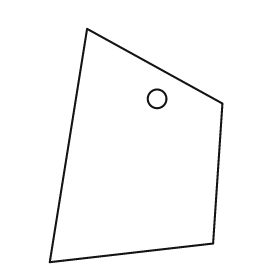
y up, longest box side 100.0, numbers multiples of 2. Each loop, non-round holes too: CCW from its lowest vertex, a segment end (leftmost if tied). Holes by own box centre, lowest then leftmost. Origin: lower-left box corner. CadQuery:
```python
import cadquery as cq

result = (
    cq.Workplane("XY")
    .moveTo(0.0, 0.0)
    .lineTo(70.0, 8.0)
    .lineTo(74.0, 68.0)
    .lineTo(16.0, 100.0)
    .close()
    .moveTo(46.0, 70.0)
    .circle(4.0)
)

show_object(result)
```